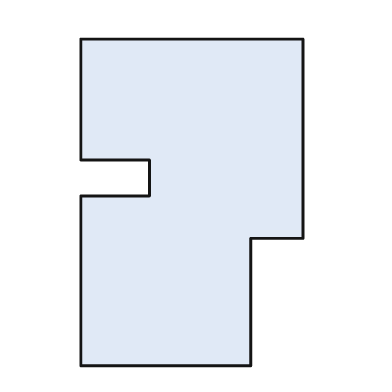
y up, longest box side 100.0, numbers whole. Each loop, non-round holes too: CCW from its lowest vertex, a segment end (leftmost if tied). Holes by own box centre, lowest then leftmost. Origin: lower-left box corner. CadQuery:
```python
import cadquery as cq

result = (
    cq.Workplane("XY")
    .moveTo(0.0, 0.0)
    .lineTo(52.0, 0.0)
    .lineTo(52.0, 39.0)
    .lineTo(68.0, 39.0)
    .lineTo(68.0, 100.0)
    .lineTo(0.0, 100.0)
    .lineTo(0.0, 63.0)
    .lineTo(21.0, 63.0)
    .lineTo(21.0, 52.0)
    .lineTo(0.0, 52.0)
    .close()
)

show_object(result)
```